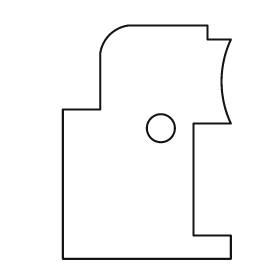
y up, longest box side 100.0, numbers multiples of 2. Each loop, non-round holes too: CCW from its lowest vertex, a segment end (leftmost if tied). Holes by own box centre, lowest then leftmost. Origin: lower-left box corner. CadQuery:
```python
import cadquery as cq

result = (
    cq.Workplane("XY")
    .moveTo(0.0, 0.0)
    .lineTo(72.0, 0.0)
    .lineTo(72.0, 10.0)
    .lineTo(56.0, 10.0)
    .lineTo(56.0, 58.0)
    .lineTo(72.0, 58.0)
    .threePointArc((68.0, 76.0), (72.0, 94.0))
    .lineTo(62.0, 94.0)
    .lineTo(62.0, 100.0)
    .lineTo(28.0, 100.0)
    .threePointArc((20.0, 96.0), (16.0, 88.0))
    .lineTo(16.0, 64.0)
    .lineTo(0.0, 64.0)
    .close()
    .moveTo(42.0, 56.0)
    .circle(6.0)
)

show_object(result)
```